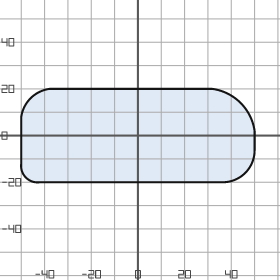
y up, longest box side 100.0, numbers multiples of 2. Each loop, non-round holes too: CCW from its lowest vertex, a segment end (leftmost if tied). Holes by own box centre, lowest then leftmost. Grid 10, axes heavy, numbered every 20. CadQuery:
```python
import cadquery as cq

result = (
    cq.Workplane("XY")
    .moveTo(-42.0, -20.0)
    .lineTo(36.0, -20.0)
    .threePointArc((46.0, -16.0), (50.0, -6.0))
    .lineTo(50.0, 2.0)
    .threePointArc((44.0, 14.0), (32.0, 20.0))
    .lineTo(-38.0, 20.0)
    .threePointArc((-46.0, 16.0), (-50.0, 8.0))
    .lineTo(-50.0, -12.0)
    .threePointArc((-48.0, -18.0), (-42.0, -20.0))
    .close()
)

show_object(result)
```